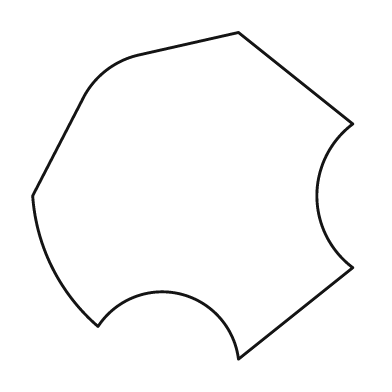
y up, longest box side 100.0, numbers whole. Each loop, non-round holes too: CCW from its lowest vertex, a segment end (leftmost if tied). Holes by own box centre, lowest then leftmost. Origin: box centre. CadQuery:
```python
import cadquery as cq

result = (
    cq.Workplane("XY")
    .moveTo(14.0, -50.0)
    .lineTo(49.0, -22.0)
    .threePointArc((38.0, 0.0), (49.0, 22.0))
    .lineTo(14.0, 50.0)
    .lineTo(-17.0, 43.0)
    .threePointArc((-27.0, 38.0), (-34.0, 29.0))
    .lineTo(-49.0, 0.0)
    .threePointArc((-43.0, -22.0), (-29.0, -40.0))
    .threePointArc((-4.0, -30.0), (14.0, -50.0))
    .close()
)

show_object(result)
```